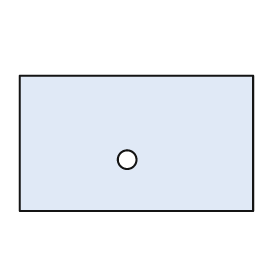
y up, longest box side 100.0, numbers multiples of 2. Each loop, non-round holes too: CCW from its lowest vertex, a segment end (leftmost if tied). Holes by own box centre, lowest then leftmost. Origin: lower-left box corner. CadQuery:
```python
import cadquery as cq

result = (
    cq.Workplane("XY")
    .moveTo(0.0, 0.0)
    .lineTo(100.0, 0.0)
    .lineTo(100.0, 58.0)
    .lineTo(0.0, 58.0)
    .close()
    .moveTo(46.0, 22.0)
    .circle(4.0)
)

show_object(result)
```